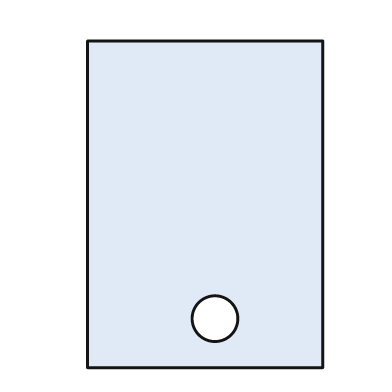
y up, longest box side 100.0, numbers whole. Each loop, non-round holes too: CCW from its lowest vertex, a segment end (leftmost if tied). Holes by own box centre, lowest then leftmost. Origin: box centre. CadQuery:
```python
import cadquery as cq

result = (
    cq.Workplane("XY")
    .moveTo(-36.0, -50.0)
    .lineTo(36.0, -50.0)
    .lineTo(36.0, 50.0)
    .lineTo(-36.0, 50.0)
    .close()
    .moveTo(3.0, -35.0)
    .circle(7.0)
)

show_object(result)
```